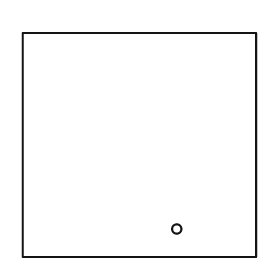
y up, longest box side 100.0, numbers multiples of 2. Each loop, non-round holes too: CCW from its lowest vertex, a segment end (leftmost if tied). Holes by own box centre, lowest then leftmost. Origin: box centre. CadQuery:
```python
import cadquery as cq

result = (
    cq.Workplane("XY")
    .moveTo(-50.0, -48.0)
    .lineTo(50.0, -48.0)
    .lineTo(50.0, 48.0)
    .lineTo(-50.0, 48.0)
    .close()
    .moveTo(16.0, -36.0)
    .circle(2.0)
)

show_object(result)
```